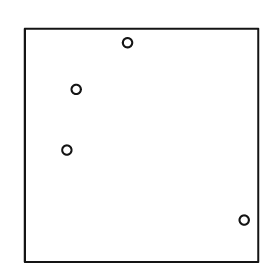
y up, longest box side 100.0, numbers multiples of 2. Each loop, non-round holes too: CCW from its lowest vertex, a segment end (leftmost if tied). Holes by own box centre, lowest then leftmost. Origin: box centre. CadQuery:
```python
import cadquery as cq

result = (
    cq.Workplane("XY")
    .moveTo(-50.0, -50.0)
    .lineTo(50.0, -50.0)
    .lineTo(50.0, 50.0)
    .lineTo(-50.0, 50.0)
    .close()
    .moveTo(44.0, -32.0)
    .circle(2.0)
    .moveTo(-32.0, -2.0)
    .circle(2.0)
    .moveTo(-28.0, 24.0)
    .circle(2.0)
    .moveTo(-6.0, 44.0)
    .circle(2.0)
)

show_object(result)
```